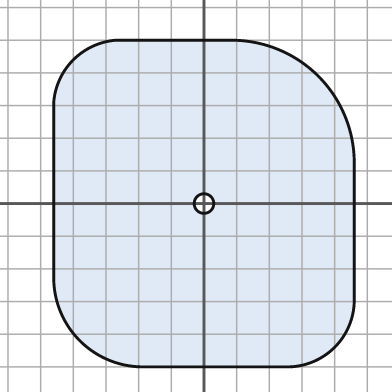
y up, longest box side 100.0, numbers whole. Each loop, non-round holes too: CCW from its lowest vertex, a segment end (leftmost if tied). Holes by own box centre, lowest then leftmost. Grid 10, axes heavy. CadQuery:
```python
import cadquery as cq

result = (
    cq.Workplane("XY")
    .moveTo(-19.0, -50.0)
    .lineTo(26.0, -50.0)
    .threePointArc((40.0, -44.0), (46.0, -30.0))
    .lineTo(46.0, 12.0)
    .threePointArc((35.0, 39.0), (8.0, 50.0))
    .lineTo(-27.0, 50.0)
    .threePointArc((-40.0, 44.0), (-46.0, 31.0))
    .lineTo(-46.0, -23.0)
    .threePointArc((-38.0, -42.0), (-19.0, -50.0))
    .close()
    .moveTo(0.0, 0.0)
    .circle(3.0)
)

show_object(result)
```